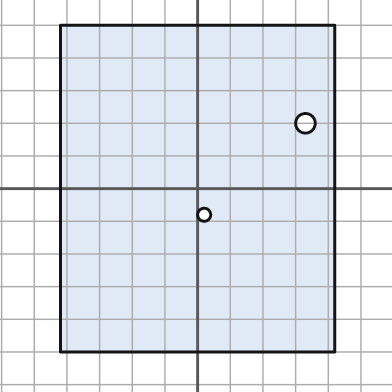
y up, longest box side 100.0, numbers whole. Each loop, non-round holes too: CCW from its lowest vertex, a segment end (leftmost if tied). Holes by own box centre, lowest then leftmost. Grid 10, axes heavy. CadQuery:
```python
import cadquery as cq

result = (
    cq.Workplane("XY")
    .moveTo(-42.0, -50.0)
    .lineTo(42.0, -50.0)
    .lineTo(42.0, 50.0)
    .lineTo(-42.0, 50.0)
    .close()
    .moveTo(2.0, -8.0)
    .circle(2.0)
    .moveTo(33.0, 20.0)
    .circle(3.0)
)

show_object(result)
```